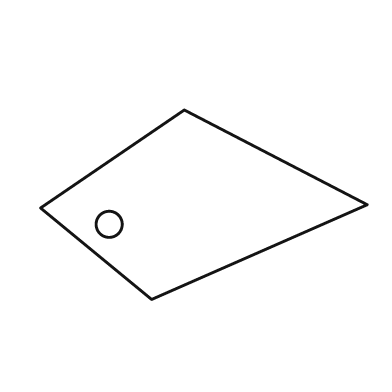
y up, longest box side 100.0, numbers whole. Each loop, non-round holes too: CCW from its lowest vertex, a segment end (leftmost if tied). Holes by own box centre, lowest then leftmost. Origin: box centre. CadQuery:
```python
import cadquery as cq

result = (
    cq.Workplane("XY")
    .moveTo(-16.0, -29.0)
    .lineTo(50.0, 0.0)
    .lineTo(-6.0, 29.0)
    .lineTo(-50.0, -1.0)
    .close()
    .moveTo(-29.0, -6.0)
    .circle(4.0)
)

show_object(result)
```